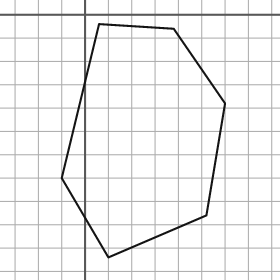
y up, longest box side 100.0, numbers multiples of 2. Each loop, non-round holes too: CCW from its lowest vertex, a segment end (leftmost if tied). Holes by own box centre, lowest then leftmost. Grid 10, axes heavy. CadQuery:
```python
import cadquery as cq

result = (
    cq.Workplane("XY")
    .moveTo(10.0, -104.0)
    .lineTo(52.0, -86.0)
    .lineTo(60.0, -38.0)
    .lineTo(38.0, -6.0)
    .lineTo(6.0, -4.0)
    .lineTo(-10.0, -70.0)
    .close()
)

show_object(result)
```